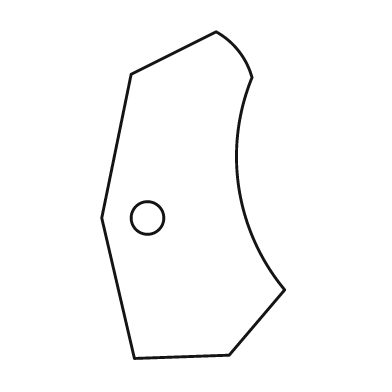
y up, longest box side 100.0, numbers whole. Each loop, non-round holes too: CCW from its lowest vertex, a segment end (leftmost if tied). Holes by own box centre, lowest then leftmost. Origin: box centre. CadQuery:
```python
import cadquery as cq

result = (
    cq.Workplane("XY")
    .moveTo(-18.0, -50.0)
    .lineTo(11.0, -49.0)
    .lineTo(28.0, -29.0)
    .threePointArc((14.0, 2.0), (18.0, 36.0))
    .threePointArc((14.0, 44.0), (7.0, 50.0))
    .lineTo(-19.0, 37.0)
    .lineTo(-28.0, -7.0)
    .close()
    .moveTo(-14.0, -7.0)
    .circle(5.0)
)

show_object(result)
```